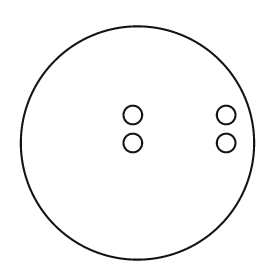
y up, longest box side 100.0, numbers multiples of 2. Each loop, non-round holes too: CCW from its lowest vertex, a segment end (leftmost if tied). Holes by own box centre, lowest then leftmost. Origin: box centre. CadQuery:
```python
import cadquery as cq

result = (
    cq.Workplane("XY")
    .moveTo(0.0, 0.0)
    .circle(50.0)
    .moveTo(-2.0, 0.0)
    .circle(4.0)
    .moveTo(38.0, 0.0)
    .circle(4.0)
    .moveTo(-2.0, 12.0)
    .circle(4.0)
    .moveTo(38.0, 12.0)
    .circle(4.0)
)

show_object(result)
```